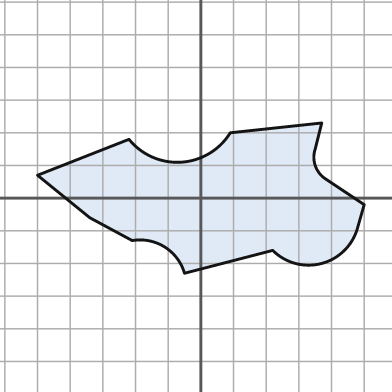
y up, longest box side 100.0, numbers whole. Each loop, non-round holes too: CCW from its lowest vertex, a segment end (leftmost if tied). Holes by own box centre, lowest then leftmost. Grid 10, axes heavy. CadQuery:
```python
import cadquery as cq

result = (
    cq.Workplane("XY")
    .moveTo(-5.0, -23.0)
    .lineTo(22.0, -16.0)
    .threePointArc((37.0, -20.0), (48.0, -9.0))
    .lineTo(50.0, -2.0)
    .lineTo(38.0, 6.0)
    .threePointArc((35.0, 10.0), (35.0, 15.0))
    .lineTo(37.0, 23.0)
    .lineTo(9.0, 20.0)
    .threePointArc((-6.0, 11.0), (-22.0, 18.0))
    .lineTo(-50.0, 7.0)
    .lineTo(-34.0, -6.0)
    .lineTo(-21.0, -13.0)
    .threePointArc((-11.0, -15.0), (-5.0, -23.0))
    .close()
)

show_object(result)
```